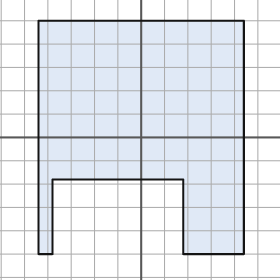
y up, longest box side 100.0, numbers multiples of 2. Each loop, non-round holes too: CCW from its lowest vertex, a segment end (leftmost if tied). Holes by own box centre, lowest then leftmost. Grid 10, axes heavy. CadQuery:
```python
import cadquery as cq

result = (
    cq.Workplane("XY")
    .moveTo(-44.0, -50.0)
    .lineTo(-38.0, -50.0)
    .lineTo(-38.0, -18.0)
    .lineTo(18.0, -18.0)
    .lineTo(18.0, -50.0)
    .lineTo(44.0, -50.0)
    .lineTo(44.0, 50.0)
    .lineTo(-44.0, 50.0)
    .close()
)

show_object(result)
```